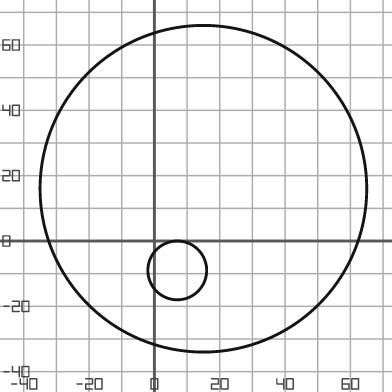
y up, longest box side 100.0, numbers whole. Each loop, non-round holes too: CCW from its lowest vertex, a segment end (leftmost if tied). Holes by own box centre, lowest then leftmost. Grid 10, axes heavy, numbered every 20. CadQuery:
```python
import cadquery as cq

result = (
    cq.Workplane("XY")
    .moveTo(15.0, 16.0)
    .circle(50.0)
    .moveTo(7.0, -9.0)
    .circle(9.0)
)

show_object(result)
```